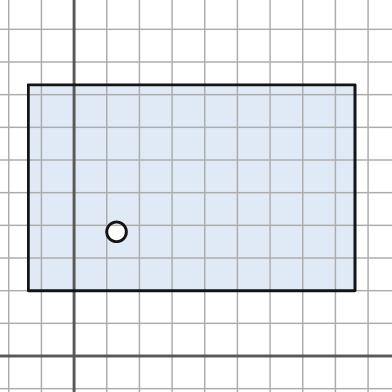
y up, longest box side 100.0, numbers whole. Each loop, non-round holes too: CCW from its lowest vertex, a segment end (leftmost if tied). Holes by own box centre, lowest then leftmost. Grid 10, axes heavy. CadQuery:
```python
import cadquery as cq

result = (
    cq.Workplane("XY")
    .moveTo(-14.0, 20.0)
    .lineTo(86.0, 20.0)
    .lineTo(86.0, 83.0)
    .lineTo(-14.0, 83.0)
    .close()
    .moveTo(13.0, 38.0)
    .circle(3.0)
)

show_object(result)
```